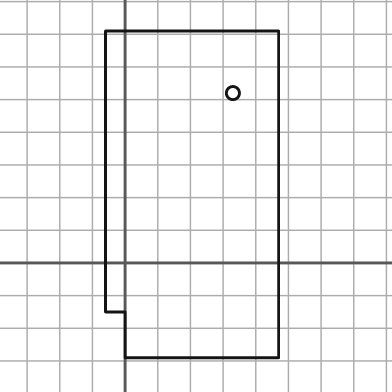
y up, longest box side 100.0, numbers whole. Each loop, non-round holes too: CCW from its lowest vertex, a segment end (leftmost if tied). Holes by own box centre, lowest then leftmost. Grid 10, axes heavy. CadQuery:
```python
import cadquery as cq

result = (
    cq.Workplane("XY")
    .moveTo(0.0, -29.0)
    .lineTo(47.0, -29.0)
    .lineTo(47.0, 71.0)
    .lineTo(-6.0, 71.0)
    .lineTo(-6.0, -15.0)
    .lineTo(0.0, -15.0)
    .close()
    .moveTo(33.0, 52.0)
    .circle(2.0)
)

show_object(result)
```